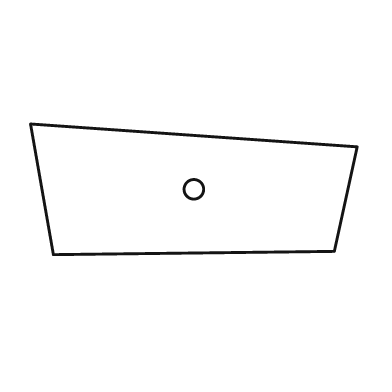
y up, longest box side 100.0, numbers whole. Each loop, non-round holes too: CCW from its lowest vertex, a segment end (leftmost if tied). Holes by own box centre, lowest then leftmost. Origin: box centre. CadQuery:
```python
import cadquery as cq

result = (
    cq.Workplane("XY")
    .moveTo(-43.0, -20.0)
    .lineTo(43.0, -19.0)
    .lineTo(50.0, 13.0)
    .lineTo(-50.0, 20.0)
    .close()
    .moveTo(0.0, 0.0)
    .circle(3.0)
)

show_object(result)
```